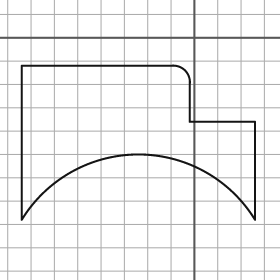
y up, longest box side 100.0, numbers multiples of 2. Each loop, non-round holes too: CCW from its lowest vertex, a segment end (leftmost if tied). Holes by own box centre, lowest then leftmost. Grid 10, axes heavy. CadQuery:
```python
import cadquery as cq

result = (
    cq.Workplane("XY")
    .moveTo(-74.0, -78.0)
    .threePointArc((-24.0, -50.0), (26.0, -78.0))
    .lineTo(26.0, -36.0)
    .lineTo(-2.0, -36.0)
    .lineTo(-2.0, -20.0)
    .threePointArc((-4.0, -14.0), (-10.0, -12.0))
    .lineTo(-74.0, -12.0)
    .close()
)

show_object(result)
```